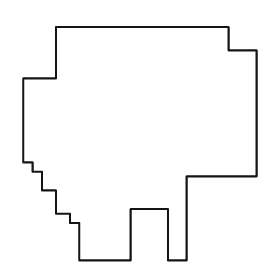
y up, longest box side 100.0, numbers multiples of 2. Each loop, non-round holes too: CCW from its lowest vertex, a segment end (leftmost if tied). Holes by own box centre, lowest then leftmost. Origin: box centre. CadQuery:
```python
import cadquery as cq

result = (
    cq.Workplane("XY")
    .moveTo(-26.0, -50.0)
    .lineTo(-4.0, -50.0)
    .lineTo(-4.0, -28.0)
    .lineTo(12.0, -28.0)
    .lineTo(12.0, -50.0)
    .lineTo(20.0, -50.0)
    .lineTo(20.0, -14.0)
    .lineTo(50.0, -14.0)
    .lineTo(50.0, 40.0)
    .lineTo(38.0, 40.0)
    .lineTo(38.0, 50.0)
    .lineTo(-36.0, 50.0)
    .lineTo(-36.0, 28.0)
    .lineTo(-50.0, 28.0)
    .lineTo(-50.0, -8.0)
    .lineTo(-46.0, -8.0)
    .lineTo(-46.0, -12.0)
    .lineTo(-42.0, -12.0)
    .lineTo(-42.0, -20.0)
    .lineTo(-36.0, -20.0)
    .lineTo(-36.0, -30.0)
    .lineTo(-30.0, -30.0)
    .lineTo(-30.0, -34.0)
    .lineTo(-26.0, -34.0)
    .close()
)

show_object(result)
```